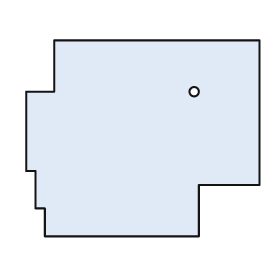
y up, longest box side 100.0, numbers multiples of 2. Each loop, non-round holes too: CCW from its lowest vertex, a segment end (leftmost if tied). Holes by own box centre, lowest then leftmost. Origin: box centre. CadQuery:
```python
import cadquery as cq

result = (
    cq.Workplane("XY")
    .moveTo(-42.0, -42.0)
    .lineTo(24.0, -42.0)
    .lineTo(24.0, -20.0)
    .lineTo(50.0, -20.0)
    .lineTo(50.0, 42.0)
    .lineTo(-38.0, 42.0)
    .lineTo(-38.0, 20.0)
    .lineTo(-50.0, 20.0)
    .lineTo(-50.0, -14.0)
    .lineTo(-46.0, -14.0)
    .lineTo(-46.0, -30.0)
    .lineTo(-42.0, -30.0)
    .close()
    .moveTo(22.0, 20.0)
    .circle(2.0)
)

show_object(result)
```